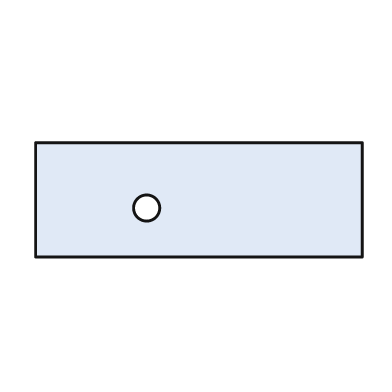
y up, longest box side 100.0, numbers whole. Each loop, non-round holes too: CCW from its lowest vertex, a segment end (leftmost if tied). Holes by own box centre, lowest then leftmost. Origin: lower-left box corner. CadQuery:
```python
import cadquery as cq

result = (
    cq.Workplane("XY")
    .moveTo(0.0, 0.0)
    .lineTo(100.0, 0.0)
    .lineTo(100.0, 35.0)
    .lineTo(0.0, 35.0)
    .close()
    .moveTo(34.0, 15.0)
    .circle(4.0)
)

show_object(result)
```